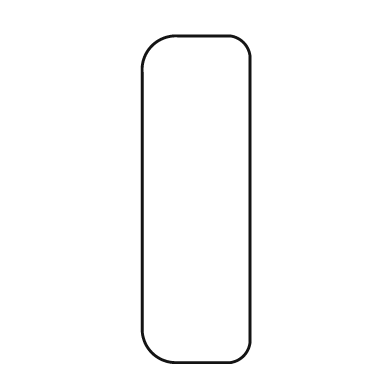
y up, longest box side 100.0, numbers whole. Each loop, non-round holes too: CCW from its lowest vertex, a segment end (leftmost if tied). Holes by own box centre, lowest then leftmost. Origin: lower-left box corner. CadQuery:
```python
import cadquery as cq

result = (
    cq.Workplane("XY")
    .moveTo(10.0, 0.0)
    .lineTo(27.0, 0.0)
    .threePointArc((31.0, 2.0), (33.0, 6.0))
    .lineTo(33.0, 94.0)
    .threePointArc((31.0, 98.0), (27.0, 100.0))
    .lineTo(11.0, 100.0)
    .threePointArc((3.0, 97.0), (0.0, 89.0))
    .lineTo(0.0, 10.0)
    .threePointArc((3.0, 3.0), (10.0, 0.0))
    .close()
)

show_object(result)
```